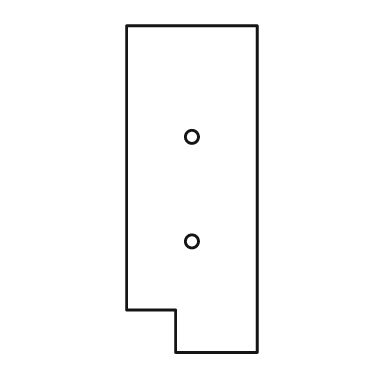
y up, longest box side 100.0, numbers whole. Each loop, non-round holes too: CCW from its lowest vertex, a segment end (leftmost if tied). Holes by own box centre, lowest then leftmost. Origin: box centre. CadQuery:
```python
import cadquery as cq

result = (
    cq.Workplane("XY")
    .moveTo(-5.0, -50.0)
    .lineTo(20.0, -50.0)
    .lineTo(20.0, 50.0)
    .lineTo(-20.0, 50.0)
    .lineTo(-20.0, -37.0)
    .lineTo(-5.0, -37.0)
    .close()
    .moveTo(0.0, -16.0)
    .circle(2.0)
    .moveTo(0.0, 16.0)
    .circle(2.0)
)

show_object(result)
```